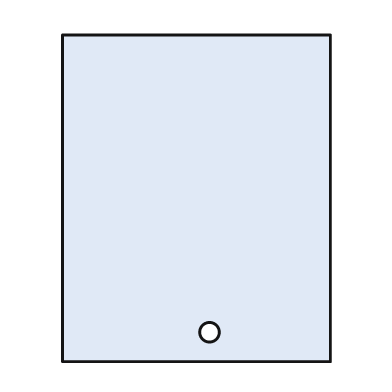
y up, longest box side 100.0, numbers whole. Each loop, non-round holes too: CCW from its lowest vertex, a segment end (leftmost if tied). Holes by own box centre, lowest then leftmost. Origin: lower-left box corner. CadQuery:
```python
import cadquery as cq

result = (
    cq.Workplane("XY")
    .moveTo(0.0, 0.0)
    .lineTo(82.0, 0.0)
    .lineTo(82.0, 100.0)
    .lineTo(0.0, 100.0)
    .close()
    .moveTo(45.0, 9.0)
    .circle(3.0)
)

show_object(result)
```